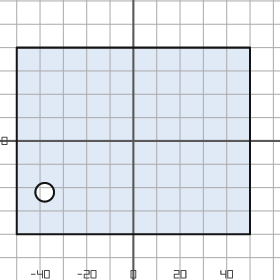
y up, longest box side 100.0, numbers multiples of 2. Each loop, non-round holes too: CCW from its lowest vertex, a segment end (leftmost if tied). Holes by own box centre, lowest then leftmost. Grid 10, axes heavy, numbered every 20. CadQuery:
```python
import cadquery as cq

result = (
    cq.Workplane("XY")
    .moveTo(-50.0, -40.0)
    .lineTo(50.0, -40.0)
    .lineTo(50.0, 40.0)
    .lineTo(-50.0, 40.0)
    .close()
    .moveTo(-38.0, -22.0)
    .circle(4.0)
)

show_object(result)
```